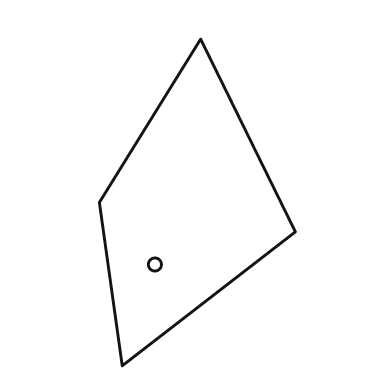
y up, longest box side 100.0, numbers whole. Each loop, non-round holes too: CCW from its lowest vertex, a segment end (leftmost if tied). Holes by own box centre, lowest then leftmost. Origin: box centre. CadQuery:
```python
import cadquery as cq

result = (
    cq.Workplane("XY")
    .moveTo(-23.0, -50.0)
    .lineTo(30.0, -9.0)
    .lineTo(1.0, 50.0)
    .lineTo(-30.0, 0.0)
    .close()
    .moveTo(-13.0, -19.0)
    .circle(2.0)
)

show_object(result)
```